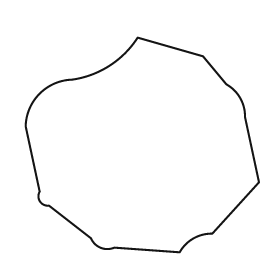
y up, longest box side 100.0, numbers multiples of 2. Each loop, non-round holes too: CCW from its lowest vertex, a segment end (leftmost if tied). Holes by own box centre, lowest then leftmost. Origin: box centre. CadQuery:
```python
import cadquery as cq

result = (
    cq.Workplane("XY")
    .moveTo(16.0, -46.0)
    .threePointArc((22.0, -40.0), (30.0, -38.0))
    .lineTo(50.0, -16.0)
    .lineTo(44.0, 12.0)
    .threePointArc((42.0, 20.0), (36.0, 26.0))
    .lineTo(26.0, 38.0)
    .lineTo(-2.0, 46.0)
    .threePointArc((-14.0, 34.0), (-30.0, 28.0))
    .threePointArc((-44.0, 22.0), (-50.0, 8.0))
    .lineTo(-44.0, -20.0)
    .threePointArc((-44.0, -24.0), (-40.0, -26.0))
    .lineTo(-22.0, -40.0)
    .threePointArc((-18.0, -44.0), (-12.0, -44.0))
    .close()
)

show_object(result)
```